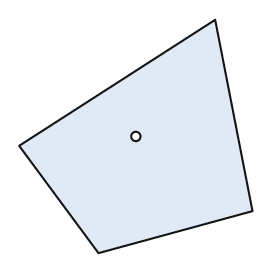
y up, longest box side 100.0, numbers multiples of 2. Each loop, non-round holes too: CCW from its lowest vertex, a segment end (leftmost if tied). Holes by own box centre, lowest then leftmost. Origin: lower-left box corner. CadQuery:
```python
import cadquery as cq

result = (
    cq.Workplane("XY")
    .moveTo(34.0, 0.0)
    .lineTo(100.0, 18.0)
    .lineTo(84.0, 100.0)
    .lineTo(0.0, 46.0)
    .close()
    .moveTo(50.0, 50.0)
    .circle(2.0)
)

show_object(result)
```